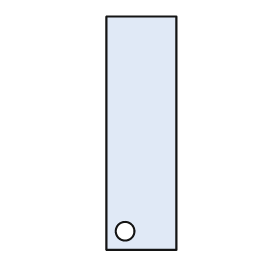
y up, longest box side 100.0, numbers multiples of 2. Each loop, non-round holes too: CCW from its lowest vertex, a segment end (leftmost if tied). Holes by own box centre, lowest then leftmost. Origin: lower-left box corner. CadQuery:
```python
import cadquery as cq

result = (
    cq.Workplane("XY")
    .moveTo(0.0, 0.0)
    .lineTo(30.0, 0.0)
    .lineTo(30.0, 100.0)
    .lineTo(0.0, 100.0)
    .close()
    .moveTo(8.0, 8.0)
    .circle(4.0)
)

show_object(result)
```